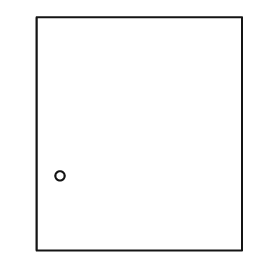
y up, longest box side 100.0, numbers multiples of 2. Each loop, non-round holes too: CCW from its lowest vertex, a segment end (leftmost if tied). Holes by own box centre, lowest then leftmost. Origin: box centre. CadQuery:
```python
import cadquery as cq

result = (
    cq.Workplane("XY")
    .moveTo(-44.0, -50.0)
    .lineTo(44.0, -50.0)
    .lineTo(44.0, 50.0)
    .lineTo(-44.0, 50.0)
    .close()
    .moveTo(-34.0, -18.0)
    .circle(2.0)
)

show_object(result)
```